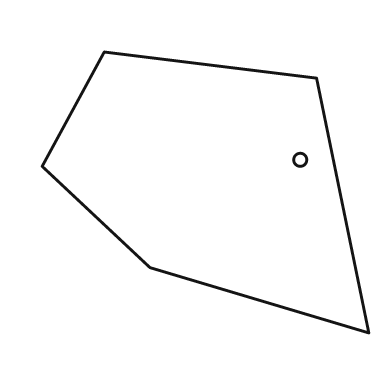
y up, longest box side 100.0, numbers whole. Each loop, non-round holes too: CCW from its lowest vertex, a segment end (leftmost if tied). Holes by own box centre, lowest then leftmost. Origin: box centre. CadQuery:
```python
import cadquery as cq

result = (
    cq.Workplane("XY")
    .moveTo(50.0, -43.0)
    .lineTo(34.0, 35.0)
    .lineTo(-31.0, 43.0)
    .lineTo(-50.0, 8.0)
    .lineTo(-17.0, -23.0)
    .close()
    .moveTo(29.0, 10.0)
    .circle(2.0)
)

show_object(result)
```